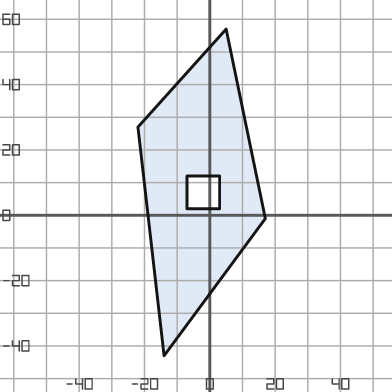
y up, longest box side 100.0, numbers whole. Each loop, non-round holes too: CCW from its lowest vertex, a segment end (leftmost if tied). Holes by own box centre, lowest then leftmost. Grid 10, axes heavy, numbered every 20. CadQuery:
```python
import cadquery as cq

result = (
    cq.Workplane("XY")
    .moveTo(-14.0, -43.0)
    .lineTo(17.0, -1.0)
    .lineTo(5.0, 57.0)
    .lineTo(-22.0, 27.0)
    .close()
    .moveTo(-7.0, 2.0)
    .lineTo(3.0, 2.0)
    .lineTo(3.0, 12.0)
    .lineTo(-7.0, 12.0)
    .close()
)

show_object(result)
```